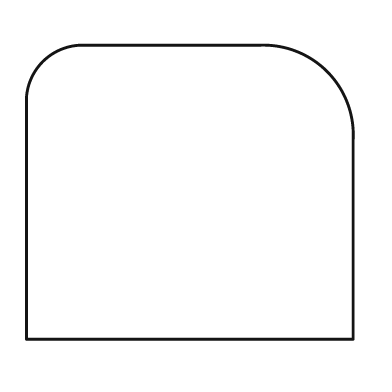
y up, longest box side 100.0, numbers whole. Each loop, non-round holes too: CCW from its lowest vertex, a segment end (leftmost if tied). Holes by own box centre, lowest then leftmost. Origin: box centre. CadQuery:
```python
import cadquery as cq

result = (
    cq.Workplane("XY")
    .moveTo(-50.0, -45.0)
    .lineTo(50.0, -45.0)
    .lineTo(50.0, 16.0)
    .threePointArc((42.0, 37.0), (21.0, 45.0))
    .lineTo(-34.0, 45.0)
    .threePointArc((-45.0, 40.0), (-50.0, 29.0))
    .close()
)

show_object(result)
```